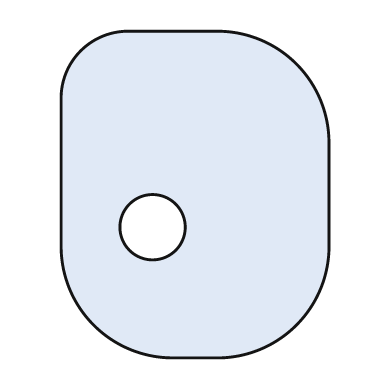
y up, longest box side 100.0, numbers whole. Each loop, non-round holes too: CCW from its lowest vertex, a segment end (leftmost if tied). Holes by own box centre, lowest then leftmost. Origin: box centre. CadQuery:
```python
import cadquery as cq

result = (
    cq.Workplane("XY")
    .moveTo(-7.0, -50.0)
    .lineTo(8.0, -50.0)
    .threePointArc((31.0, -40.0), (41.0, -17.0))
    .lineTo(41.0, 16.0)
    .threePointArc((31.0, 40.0), (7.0, 50.0))
    .lineTo(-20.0, 50.0)
    .threePointArc((-35.0, 44.0), (-41.0, 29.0))
    .lineTo(-41.0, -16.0)
    .threePointArc((-31.0, -40.0), (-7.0, -50.0))
    .close()
    .moveTo(-13.0, -10.0)
    .circle(10.0)
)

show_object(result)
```